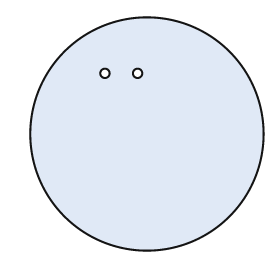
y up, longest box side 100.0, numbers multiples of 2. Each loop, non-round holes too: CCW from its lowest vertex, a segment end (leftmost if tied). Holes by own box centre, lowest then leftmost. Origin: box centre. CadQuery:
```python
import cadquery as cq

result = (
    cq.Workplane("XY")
    .moveTo(0.0, 0.0)
    .circle(50.0)
    .moveTo(-18.0, 26.0)
    .circle(2.0)
    .moveTo(-4.0, 26.0)
    .circle(2.0)
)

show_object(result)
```